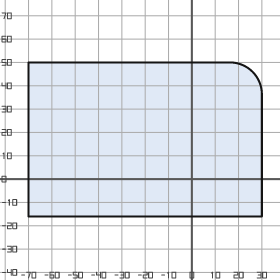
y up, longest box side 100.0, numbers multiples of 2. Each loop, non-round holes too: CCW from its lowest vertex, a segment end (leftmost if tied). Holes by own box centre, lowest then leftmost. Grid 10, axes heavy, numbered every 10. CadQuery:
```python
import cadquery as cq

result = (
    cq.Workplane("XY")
    .moveTo(-70.0, -16.0)
    .lineTo(30.0, -16.0)
    .lineTo(30.0, 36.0)
    .threePointArc((26.0, 46.0), (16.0, 50.0))
    .lineTo(-70.0, 50.0)
    .close()
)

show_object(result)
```